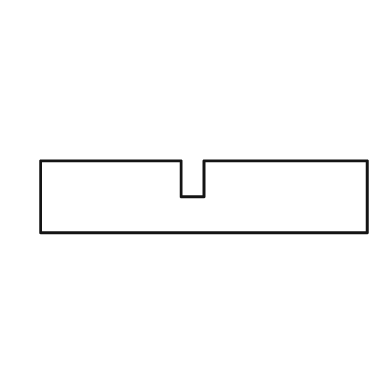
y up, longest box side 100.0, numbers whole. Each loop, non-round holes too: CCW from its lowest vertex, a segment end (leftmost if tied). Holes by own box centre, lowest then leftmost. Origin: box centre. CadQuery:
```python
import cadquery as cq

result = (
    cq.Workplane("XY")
    .moveTo(-50.0, -11.0)
    .lineTo(50.0, -11.0)
    .lineTo(50.0, 11.0)
    .lineTo(0.0, 11.0)
    .lineTo(0.0, 0.0)
    .lineTo(-7.0, 0.0)
    .lineTo(-7.0, 11.0)
    .lineTo(-50.0, 11.0)
    .close()
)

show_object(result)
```